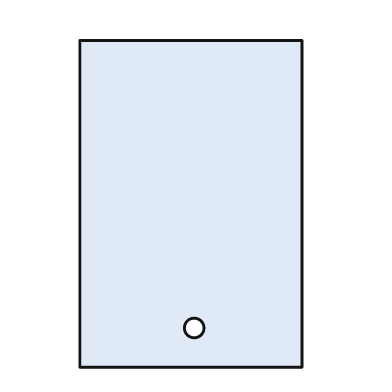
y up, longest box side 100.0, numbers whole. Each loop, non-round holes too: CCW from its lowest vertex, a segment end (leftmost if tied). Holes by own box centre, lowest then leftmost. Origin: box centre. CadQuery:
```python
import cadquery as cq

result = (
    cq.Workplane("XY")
    .moveTo(-34.0, -50.0)
    .lineTo(34.0, -50.0)
    .lineTo(34.0, 50.0)
    .lineTo(-34.0, 50.0)
    .close()
    .moveTo(1.0, -38.0)
    .circle(3.0)
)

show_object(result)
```